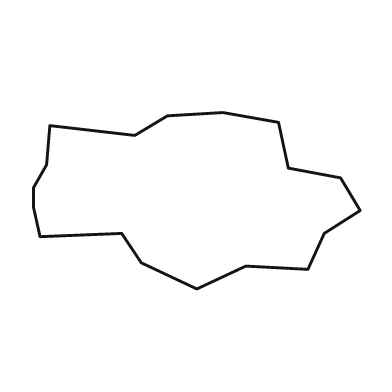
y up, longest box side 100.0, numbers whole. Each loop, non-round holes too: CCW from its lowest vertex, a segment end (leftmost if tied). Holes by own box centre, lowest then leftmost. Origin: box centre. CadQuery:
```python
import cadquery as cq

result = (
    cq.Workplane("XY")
    .moveTo(0.0, -27.0)
    .lineTo(15.0, -20.0)
    .lineTo(34.0, -21.0)
    .lineTo(39.0, -10.0)
    .lineTo(50.0, -3.0)
    .lineTo(44.0, 7.0)
    .lineTo(28.0, 10.0)
    .lineTo(25.0, 24.0)
    .lineTo(8.0, 27.0)
    .lineTo(-9.0, 26.0)
    .lineTo(-19.0, 20.0)
    .lineTo(-45.0, 23.0)
    .lineTo(-46.0, 11.0)
    .lineTo(-50.0, 4.0)
    .lineTo(-50.0, -2.0)
    .lineTo(-48.0, -11.0)
    .lineTo(-23.0, -10.0)
    .lineTo(-17.0, -19.0)
    .close()
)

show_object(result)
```